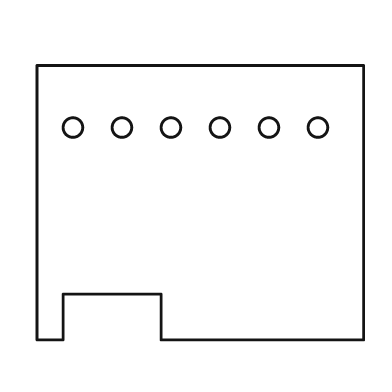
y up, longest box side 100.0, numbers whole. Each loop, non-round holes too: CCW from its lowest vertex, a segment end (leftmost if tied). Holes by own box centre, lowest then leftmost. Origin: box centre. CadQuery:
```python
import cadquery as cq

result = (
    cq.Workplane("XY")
    .moveTo(-50.0, -42.0)
    .lineTo(-42.0, -42.0)
    .lineTo(-42.0, -28.0)
    .lineTo(-12.0, -28.0)
    .lineTo(-12.0, -42.0)
    .lineTo(50.0, -42.0)
    .lineTo(50.0, 42.0)
    .lineTo(-50.0, 42.0)
    .close()
    .moveTo(-39.0, 23.0)
    .circle(3.0)
    .moveTo(-24.0, 23.0)
    .circle(3.0)
    .moveTo(-9.0, 23.0)
    .circle(3.0)
    .moveTo(6.0, 23.0)
    .circle(3.0)
    .moveTo(21.0, 23.0)
    .circle(3.0)
    .moveTo(36.0, 23.0)
    .circle(3.0)
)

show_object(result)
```